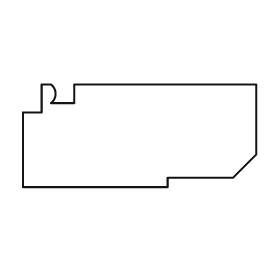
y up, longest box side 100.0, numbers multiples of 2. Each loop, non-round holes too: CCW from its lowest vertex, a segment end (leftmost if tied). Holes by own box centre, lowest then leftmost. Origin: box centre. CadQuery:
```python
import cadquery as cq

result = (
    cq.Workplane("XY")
    .moveTo(-50.0, -22.0)
    .lineTo(12.0, -22.0)
    .lineTo(12.0, -18.0)
    .lineTo(40.0, -18.0)
    .lineTo(50.0, -8.0)
    .lineTo(50.0, 22.0)
    .lineTo(-28.0, 22.0)
    .lineTo(-28.0, 14.0)
    .lineTo(-38.0, 14.0)
    .threePointArc((-36.0, 18.0), (-38.0, 22.0))
    .lineTo(-42.0, 22.0)
    .lineTo(-42.0, 10.0)
    .lineTo(-50.0, 10.0)
    .close()
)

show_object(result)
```